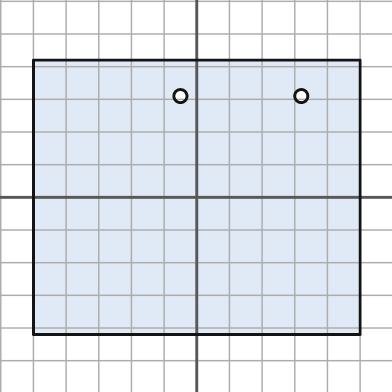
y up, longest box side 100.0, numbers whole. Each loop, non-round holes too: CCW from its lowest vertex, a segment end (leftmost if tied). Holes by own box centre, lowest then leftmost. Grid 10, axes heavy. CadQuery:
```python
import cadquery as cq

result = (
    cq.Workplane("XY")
    .moveTo(-50.0, -42.0)
    .lineTo(50.0, -42.0)
    .lineTo(50.0, 42.0)
    .lineTo(-50.0, 42.0)
    .close()
    .moveTo(-5.0, 31.0)
    .circle(2.0)
    .moveTo(32.0, 31.0)
    .circle(2.0)
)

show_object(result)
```